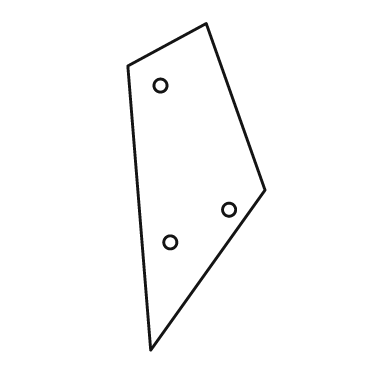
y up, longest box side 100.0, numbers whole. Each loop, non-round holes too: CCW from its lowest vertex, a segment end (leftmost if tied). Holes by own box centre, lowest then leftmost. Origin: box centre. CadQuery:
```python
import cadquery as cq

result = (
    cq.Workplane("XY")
    .moveTo(-14.0, -50.0)
    .lineTo(21.0, -1.0)
    .lineTo(3.0, 50.0)
    .lineTo(-21.0, 37.0)
    .close()
    .moveTo(-8.0, -17.0)
    .circle(2.0)
    .moveTo(10.0, -7.0)
    .circle(2.0)
    .moveTo(-11.0, 31.0)
    .circle(2.0)
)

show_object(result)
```